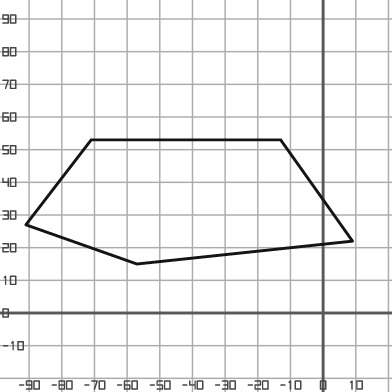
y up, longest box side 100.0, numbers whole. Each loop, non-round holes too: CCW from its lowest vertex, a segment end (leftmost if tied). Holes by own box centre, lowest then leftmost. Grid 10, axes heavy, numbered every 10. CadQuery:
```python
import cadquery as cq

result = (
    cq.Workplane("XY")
    .moveTo(-57.0, 15.0)
    .lineTo(9.0, 22.0)
    .lineTo(-13.0, 53.0)
    .lineTo(-71.0, 53.0)
    .lineTo(-91.0, 27.0)
    .close()
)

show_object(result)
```